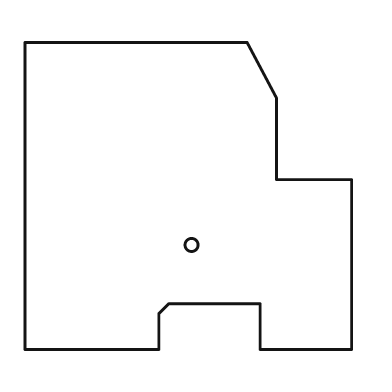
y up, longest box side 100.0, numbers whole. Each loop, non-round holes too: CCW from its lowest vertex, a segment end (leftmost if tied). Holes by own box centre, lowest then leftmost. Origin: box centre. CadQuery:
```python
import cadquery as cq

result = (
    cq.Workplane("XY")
    .moveTo(-50.0, -47.0)
    .lineTo(-9.0, -47.0)
    .lineTo(-9.0, -36.0)
    .lineTo(-6.0, -33.0)
    .lineTo(22.0, -33.0)
    .lineTo(22.0, -47.0)
    .lineTo(50.0, -47.0)
    .lineTo(50.0, 5.0)
    .lineTo(27.0, 5.0)
    .lineTo(27.0, 30.0)
    .lineTo(18.0, 47.0)
    .lineTo(-50.0, 47.0)
    .close()
    .moveTo(1.0, -15.0)
    .circle(2.0)
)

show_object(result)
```